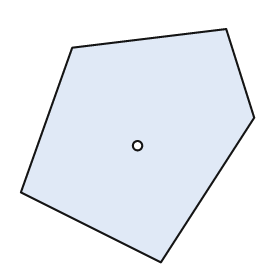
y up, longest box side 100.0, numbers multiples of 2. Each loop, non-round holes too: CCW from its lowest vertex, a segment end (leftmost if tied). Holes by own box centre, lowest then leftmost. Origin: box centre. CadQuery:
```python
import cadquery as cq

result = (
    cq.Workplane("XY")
    .moveTo(10.0, -50.0)
    .lineTo(50.0, 12.0)
    .lineTo(38.0, 50.0)
    .lineTo(-28.0, 42.0)
    .lineTo(-50.0, -20.0)
    .close()
    .moveTo(0.0, 0.0)
    .circle(2.0)
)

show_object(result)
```